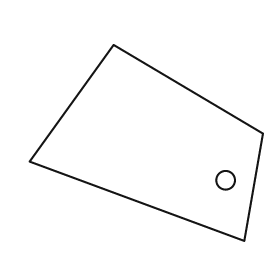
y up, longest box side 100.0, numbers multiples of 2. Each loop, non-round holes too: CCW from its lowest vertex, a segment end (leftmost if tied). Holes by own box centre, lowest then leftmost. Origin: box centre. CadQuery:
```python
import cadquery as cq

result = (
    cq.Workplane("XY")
    .moveTo(42.0, -42.0)
    .lineTo(50.0, 4.0)
    .lineTo(-14.0, 42.0)
    .lineTo(-50.0, -8.0)
    .close()
    .moveTo(34.0, -16.0)
    .circle(4.0)
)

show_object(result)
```